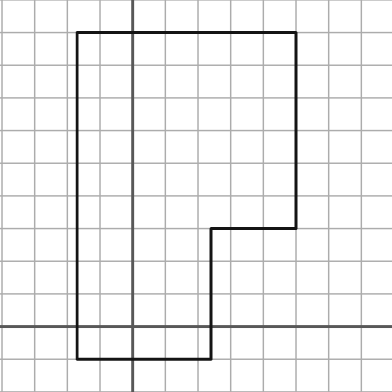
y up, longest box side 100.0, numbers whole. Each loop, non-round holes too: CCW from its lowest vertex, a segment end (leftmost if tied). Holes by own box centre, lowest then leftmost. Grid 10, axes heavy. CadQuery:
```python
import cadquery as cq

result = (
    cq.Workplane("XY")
    .moveTo(-17.0, -10.0)
    .lineTo(24.0, -10.0)
    .lineTo(24.0, 30.0)
    .lineTo(50.0, 30.0)
    .lineTo(50.0, 90.0)
    .lineTo(-17.0, 90.0)
    .close()
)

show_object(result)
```